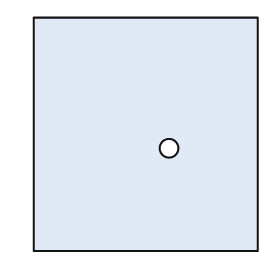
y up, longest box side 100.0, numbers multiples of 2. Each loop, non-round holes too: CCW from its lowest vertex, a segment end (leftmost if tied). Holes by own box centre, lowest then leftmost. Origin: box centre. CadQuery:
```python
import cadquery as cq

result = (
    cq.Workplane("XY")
    .moveTo(-48.0, -50.0)
    .lineTo(48.0, -50.0)
    .lineTo(48.0, 50.0)
    .lineTo(-48.0, 50.0)
    .close()
    .moveTo(10.0, -6.0)
    .circle(4.0)
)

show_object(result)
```